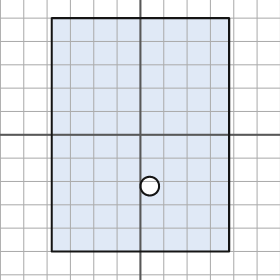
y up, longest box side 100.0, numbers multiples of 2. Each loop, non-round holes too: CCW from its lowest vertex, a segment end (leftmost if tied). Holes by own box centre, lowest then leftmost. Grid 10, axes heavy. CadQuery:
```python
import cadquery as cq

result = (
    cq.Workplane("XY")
    .moveTo(-38.0, -50.0)
    .lineTo(38.0, -50.0)
    .lineTo(38.0, 50.0)
    .lineTo(-38.0, 50.0)
    .close()
    .moveTo(4.0, -22.0)
    .circle(4.0)
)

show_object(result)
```